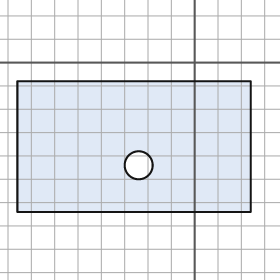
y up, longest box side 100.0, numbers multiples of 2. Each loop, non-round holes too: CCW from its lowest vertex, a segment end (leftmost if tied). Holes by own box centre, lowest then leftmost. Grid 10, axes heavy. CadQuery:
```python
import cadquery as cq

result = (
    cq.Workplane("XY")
    .moveTo(-76.0, -64.0)
    .lineTo(24.0, -64.0)
    .lineTo(24.0, -8.0)
    .lineTo(-76.0, -8.0)
    .close()
    .moveTo(-24.0, -44.0)
    .circle(6.0)
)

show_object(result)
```